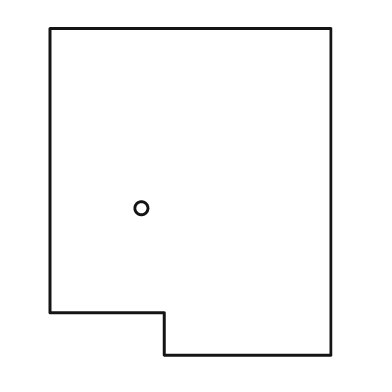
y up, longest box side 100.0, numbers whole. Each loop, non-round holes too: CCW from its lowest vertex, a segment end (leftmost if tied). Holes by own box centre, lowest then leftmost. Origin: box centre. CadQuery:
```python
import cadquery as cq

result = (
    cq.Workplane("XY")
    .moveTo(-8.0, -50.0)
    .lineTo(43.0, -50.0)
    .lineTo(43.0, 50.0)
    .lineTo(-43.0, 50.0)
    .lineTo(-43.0, -37.0)
    .lineTo(-8.0, -37.0)
    .close()
    .moveTo(-15.0, -5.0)
    .circle(2.0)
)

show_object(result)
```